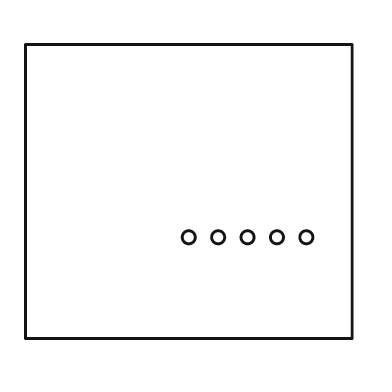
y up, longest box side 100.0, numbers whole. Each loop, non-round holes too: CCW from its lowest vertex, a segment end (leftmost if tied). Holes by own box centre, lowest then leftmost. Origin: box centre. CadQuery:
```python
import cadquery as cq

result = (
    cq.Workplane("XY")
    .moveTo(-50.0, -45.0)
    .lineTo(50.0, -45.0)
    .lineTo(50.0, 45.0)
    .lineTo(-50.0, 45.0)
    .close()
    .moveTo(0.0, -14.0)
    .circle(2.0)
    .moveTo(9.0, -14.0)
    .circle(2.0)
    .moveTo(18.0, -14.0)
    .circle(2.0)
    .moveTo(27.0, -14.0)
    .circle(2.0)
    .moveTo(36.0, -14.0)
    .circle(2.0)
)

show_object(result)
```